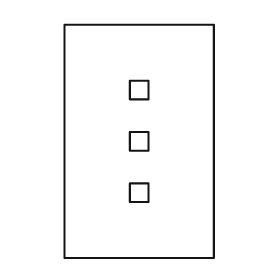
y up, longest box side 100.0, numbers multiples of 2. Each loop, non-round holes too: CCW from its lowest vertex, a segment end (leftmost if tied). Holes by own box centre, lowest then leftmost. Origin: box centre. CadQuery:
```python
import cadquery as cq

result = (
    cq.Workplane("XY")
    .moveTo(-32.0, -50.0)
    .lineTo(32.0, -50.0)
    .lineTo(32.0, 50.0)
    .lineTo(-32.0, 50.0)
    .close()
    .moveTo(-4.0, -26.0)
    .lineTo(4.0, -26.0)
    .lineTo(4.0, -18.0)
    .lineTo(-4.0, -18.0)
    .close()
    .moveTo(-4.0, -4.0)
    .lineTo(4.0, -4.0)
    .lineTo(4.0, 4.0)
    .lineTo(-4.0, 4.0)
    .close()
    .moveTo(-4.0, 18.0)
    .lineTo(4.0, 18.0)
    .lineTo(4.0, 26.0)
    .lineTo(-4.0, 26.0)
    .close()
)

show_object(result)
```